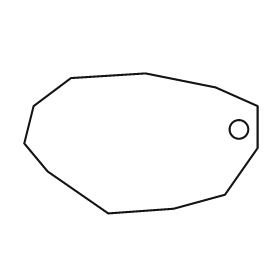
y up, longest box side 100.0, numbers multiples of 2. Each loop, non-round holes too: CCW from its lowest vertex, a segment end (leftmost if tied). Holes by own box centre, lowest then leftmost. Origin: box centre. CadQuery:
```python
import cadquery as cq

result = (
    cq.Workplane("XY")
    .moveTo(-14.0, -30.0)
    .lineTo(14.0, -28.0)
    .lineTo(36.0, -22.0)
    .lineTo(50.0, -2.0)
    .lineTo(50.0, 16.0)
    .lineTo(32.0, 24.0)
    .lineTo(2.0, 30.0)
    .lineTo(-30.0, 28.0)
    .lineTo(-46.0, 16.0)
    .lineTo(-50.0, 0.0)
    .lineTo(-40.0, -12.0)
    .close()
    .moveTo(42.0, 6.0)
    .circle(4.0)
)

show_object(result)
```